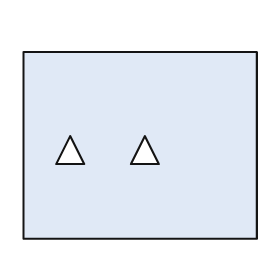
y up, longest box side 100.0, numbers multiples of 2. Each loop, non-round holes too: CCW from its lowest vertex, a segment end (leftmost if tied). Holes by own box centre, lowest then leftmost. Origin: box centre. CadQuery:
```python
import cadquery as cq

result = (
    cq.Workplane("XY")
    .moveTo(-50.0, -40.0)
    .lineTo(50.0, -40.0)
    .lineTo(50.0, 40.0)
    .lineTo(-50.0, 40.0)
    .close()
    .moveTo(-36.0, -8.0)
    .lineTo(-24.0, -8.0)
    .lineTo(-30.0, 4.0)
    .close()
    .moveTo(-4.0, -8.0)
    .lineTo(8.0, -8.0)
    .lineTo(2.0, 4.0)
    .close()
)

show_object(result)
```